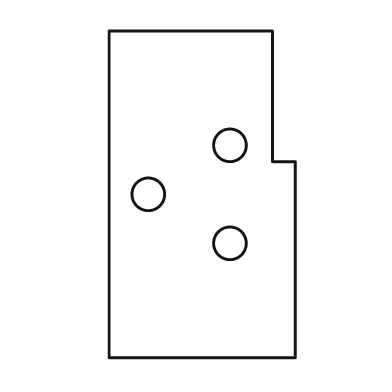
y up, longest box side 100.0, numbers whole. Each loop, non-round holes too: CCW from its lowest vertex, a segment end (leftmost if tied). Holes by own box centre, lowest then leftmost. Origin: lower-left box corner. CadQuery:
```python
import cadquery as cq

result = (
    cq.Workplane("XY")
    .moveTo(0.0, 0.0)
    .lineTo(57.0, 0.0)
    .lineTo(57.0, 60.0)
    .lineTo(50.0, 60.0)
    .lineTo(50.0, 100.0)
    .lineTo(0.0, 100.0)
    .close()
    .moveTo(37.0, 35.0)
    .circle(5.0)
    .moveTo(12.0, 50.0)
    .circle(5.0)
    .moveTo(37.0, 65.0)
    .circle(5.0)
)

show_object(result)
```